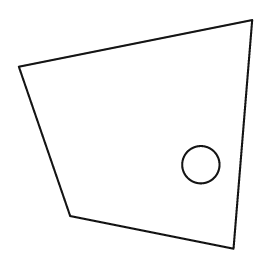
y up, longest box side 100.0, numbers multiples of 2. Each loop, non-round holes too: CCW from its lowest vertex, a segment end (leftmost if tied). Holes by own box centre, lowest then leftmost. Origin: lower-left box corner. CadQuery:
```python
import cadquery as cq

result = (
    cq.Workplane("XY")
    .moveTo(92.0, 0.0)
    .lineTo(100.0, 98.0)
    .lineTo(0.0, 78.0)
    .lineTo(22.0, 14.0)
    .close()
    .moveTo(78.0, 36.0)
    .circle(8.0)
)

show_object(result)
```